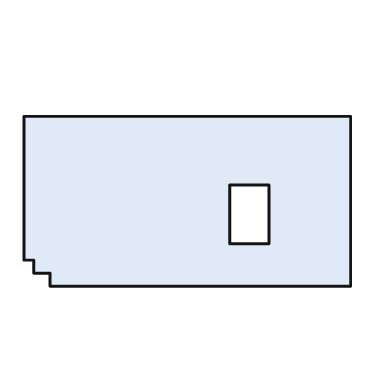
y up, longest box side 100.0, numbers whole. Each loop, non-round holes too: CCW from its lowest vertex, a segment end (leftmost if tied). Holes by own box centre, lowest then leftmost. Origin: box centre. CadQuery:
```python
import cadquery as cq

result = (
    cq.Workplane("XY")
    .moveTo(-42.0, -26.0)
    .lineTo(50.0, -26.0)
    .lineTo(50.0, 26.0)
    .lineTo(-50.0, 26.0)
    .lineTo(-50.0, -18.0)
    .lineTo(-47.0, -18.0)
    .lineTo(-47.0, -22.0)
    .lineTo(-42.0, -22.0)
    .close()
    .moveTo(13.0, -13.0)
    .lineTo(25.0, -13.0)
    .lineTo(25.0, 5.0)
    .lineTo(13.0, 5.0)
    .close()
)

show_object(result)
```